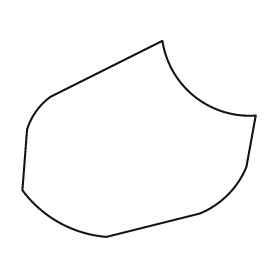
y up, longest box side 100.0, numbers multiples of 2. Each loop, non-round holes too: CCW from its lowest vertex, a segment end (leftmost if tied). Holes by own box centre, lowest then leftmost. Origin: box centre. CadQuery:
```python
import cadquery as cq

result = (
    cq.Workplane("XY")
    .moveTo(-14.0, -42.0)
    .lineTo(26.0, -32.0)
    .threePointArc((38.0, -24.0), (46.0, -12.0))
    .lineTo(50.0, 10.0)
    .threePointArc((24.0, 18.0), (10.0, 42.0))
    .lineTo(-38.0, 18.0)
    .threePointArc((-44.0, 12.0), (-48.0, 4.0))
    .lineTo(-50.0, -22.0)
    .threePointArc((-34.0, -36.0), (-14.0, -42.0))
    .close()
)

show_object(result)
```